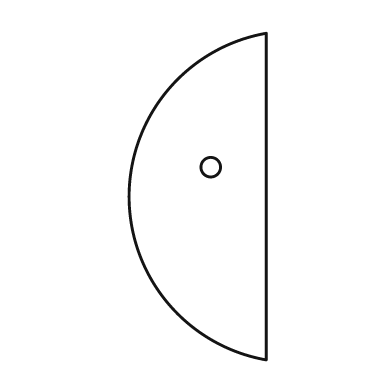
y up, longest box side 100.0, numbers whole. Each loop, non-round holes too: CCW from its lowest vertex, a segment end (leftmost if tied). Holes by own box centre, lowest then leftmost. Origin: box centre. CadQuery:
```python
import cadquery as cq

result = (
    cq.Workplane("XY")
    .moveTo(21.0, -50.0)
    .lineTo(21.0, 50.0)
    .threePointArc((-21.0, 0.0), (21.0, -50.0))
    .close()
    .moveTo(4.0, 9.0)
    .circle(3.0)
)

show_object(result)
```